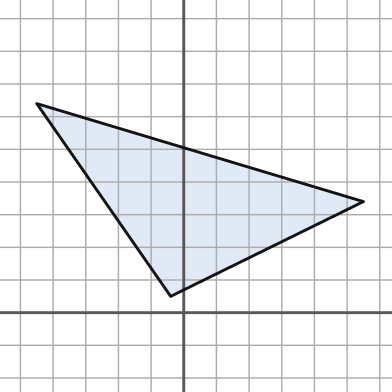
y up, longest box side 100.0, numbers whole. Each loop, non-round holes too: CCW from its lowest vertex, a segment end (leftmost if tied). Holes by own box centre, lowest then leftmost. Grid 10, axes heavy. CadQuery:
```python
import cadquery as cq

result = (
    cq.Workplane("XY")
    .moveTo(-4.0, 5.0)
    .lineTo(55.0, 34.0)
    .lineTo(-45.0, 64.0)
    .close()
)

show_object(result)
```